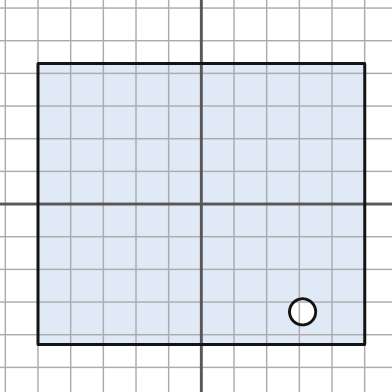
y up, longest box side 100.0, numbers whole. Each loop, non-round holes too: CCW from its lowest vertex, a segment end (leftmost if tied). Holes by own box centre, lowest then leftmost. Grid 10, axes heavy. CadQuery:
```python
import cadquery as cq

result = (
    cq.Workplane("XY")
    .moveTo(-50.0, -43.0)
    .lineTo(50.0, -43.0)
    .lineTo(50.0, 43.0)
    .lineTo(-50.0, 43.0)
    .close()
    .moveTo(31.0, -33.0)
    .circle(4.0)
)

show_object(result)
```